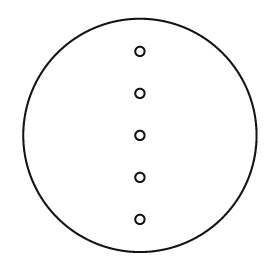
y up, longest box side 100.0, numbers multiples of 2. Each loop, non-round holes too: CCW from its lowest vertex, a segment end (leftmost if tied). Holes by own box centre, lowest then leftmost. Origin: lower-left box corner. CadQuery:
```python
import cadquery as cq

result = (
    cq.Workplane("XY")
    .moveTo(50.0, 50.0)
    .circle(50.0)
    .moveTo(50.0, 14.0)
    .circle(2.0)
    .moveTo(50.0, 32.0)
    .circle(2.0)
    .moveTo(50.0, 50.0)
    .circle(2.0)
    .moveTo(50.0, 68.0)
    .circle(2.0)
    .moveTo(50.0, 86.0)
    .circle(2.0)
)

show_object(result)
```